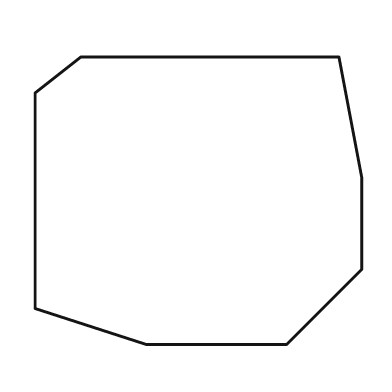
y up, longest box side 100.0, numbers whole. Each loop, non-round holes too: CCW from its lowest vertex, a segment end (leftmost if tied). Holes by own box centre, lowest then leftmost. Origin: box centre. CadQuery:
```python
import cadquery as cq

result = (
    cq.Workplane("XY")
    .moveTo(-16.0, -44.0)
    .lineTo(27.0, -44.0)
    .lineTo(50.0, -21.0)
    .lineTo(50.0, 7.0)
    .lineTo(43.0, 44.0)
    .lineTo(-36.0, 44.0)
    .lineTo(-50.0, 33.0)
    .lineTo(-50.0, -33.0)
    .close()
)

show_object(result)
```